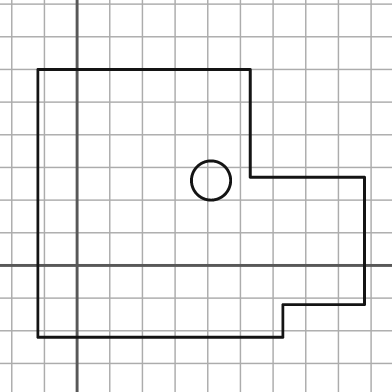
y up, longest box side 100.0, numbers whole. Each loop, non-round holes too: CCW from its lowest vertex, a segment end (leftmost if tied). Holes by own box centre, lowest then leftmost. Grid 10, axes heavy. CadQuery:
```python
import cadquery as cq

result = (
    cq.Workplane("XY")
    .moveTo(-12.0, -22.0)
    .lineTo(63.0, -22.0)
    .lineTo(63.0, -12.0)
    .lineTo(88.0, -12.0)
    .lineTo(88.0, 27.0)
    .lineTo(53.0, 27.0)
    .lineTo(53.0, 60.0)
    .lineTo(-12.0, 60.0)
    .close()
    .moveTo(41.0, 26.0)
    .circle(6.0)
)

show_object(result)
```